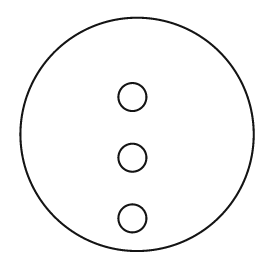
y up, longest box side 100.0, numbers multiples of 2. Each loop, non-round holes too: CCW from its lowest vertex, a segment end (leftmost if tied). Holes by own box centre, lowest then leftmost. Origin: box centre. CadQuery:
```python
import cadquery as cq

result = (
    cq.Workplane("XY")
    .moveTo(0.0, 0.0)
    .circle(50.0)
    .moveTo(-2.0, -36.0)
    .circle(6.0)
    .moveTo(-2.0, -10.0)
    .circle(6.0)
    .moveTo(-2.0, 16.0)
    .circle(6.0)
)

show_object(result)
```